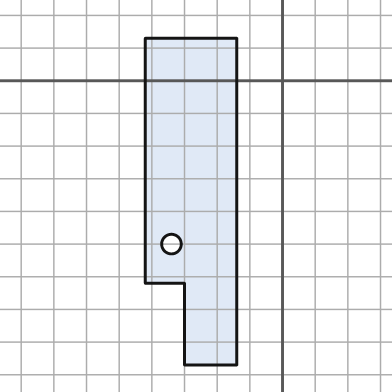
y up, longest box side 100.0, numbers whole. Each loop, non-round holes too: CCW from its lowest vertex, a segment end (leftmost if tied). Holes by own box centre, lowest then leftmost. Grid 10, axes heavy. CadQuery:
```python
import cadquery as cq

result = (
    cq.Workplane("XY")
    .moveTo(-30.0, -87.0)
    .lineTo(-14.0, -87.0)
    .lineTo(-14.0, 13.0)
    .lineTo(-42.0, 13.0)
    .lineTo(-42.0, -62.0)
    .lineTo(-30.0, -62.0)
    .close()
    .moveTo(-34.0, -50.0)
    .circle(3.0)
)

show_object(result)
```